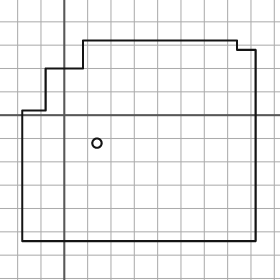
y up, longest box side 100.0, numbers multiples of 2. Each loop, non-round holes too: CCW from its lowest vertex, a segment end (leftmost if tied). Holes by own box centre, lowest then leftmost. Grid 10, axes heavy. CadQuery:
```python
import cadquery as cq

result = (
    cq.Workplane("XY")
    .moveTo(-18.0, -54.0)
    .lineTo(82.0, -54.0)
    .lineTo(82.0, 28.0)
    .lineTo(74.0, 28.0)
    .lineTo(74.0, 32.0)
    .lineTo(8.0, 32.0)
    .lineTo(8.0, 20.0)
    .lineTo(-8.0, 20.0)
    .lineTo(-8.0, 2.0)
    .lineTo(-18.0, 2.0)
    .close()
    .moveTo(14.0, -12.0)
    .circle(2.0)
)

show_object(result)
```